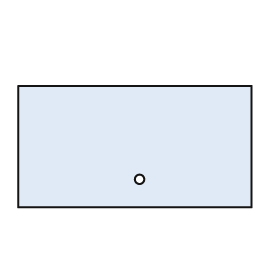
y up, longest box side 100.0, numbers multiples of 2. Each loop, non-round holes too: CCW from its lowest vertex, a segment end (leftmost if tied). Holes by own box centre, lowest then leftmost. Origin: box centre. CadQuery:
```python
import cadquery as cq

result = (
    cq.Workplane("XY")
    .moveTo(-50.0, -26.0)
    .lineTo(50.0, -26.0)
    .lineTo(50.0, 26.0)
    .lineTo(-50.0, 26.0)
    .close()
    .moveTo(2.0, -14.0)
    .circle(2.0)
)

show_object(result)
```